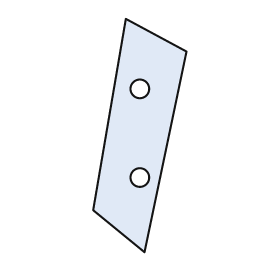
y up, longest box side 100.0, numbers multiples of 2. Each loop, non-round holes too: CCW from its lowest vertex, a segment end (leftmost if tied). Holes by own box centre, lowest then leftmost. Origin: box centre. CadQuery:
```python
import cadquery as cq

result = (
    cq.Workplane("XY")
    .moveTo(2.0, -50.0)
    .lineTo(20.0, 36.0)
    .lineTo(-6.0, 50.0)
    .lineTo(-20.0, -32.0)
    .close()
    .moveTo(0.0, -18.0)
    .circle(4.0)
    .moveTo(0.0, 20.0)
    .circle(4.0)
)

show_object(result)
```